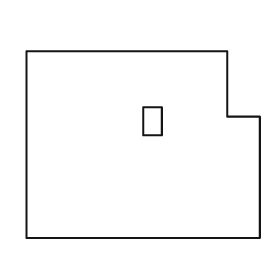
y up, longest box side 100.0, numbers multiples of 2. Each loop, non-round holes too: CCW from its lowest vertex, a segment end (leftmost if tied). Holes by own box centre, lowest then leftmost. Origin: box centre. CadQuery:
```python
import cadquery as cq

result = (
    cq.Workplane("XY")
    .moveTo(-50.0, -40.0)
    .lineTo(50.0, -40.0)
    .lineTo(50.0, 12.0)
    .lineTo(36.0, 12.0)
    .lineTo(36.0, 40.0)
    .lineTo(-50.0, 40.0)
    .close()
    .moveTo(0.0, 4.0)
    .lineTo(8.0, 4.0)
    .lineTo(8.0, 16.0)
    .lineTo(0.0, 16.0)
    .close()
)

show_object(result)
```